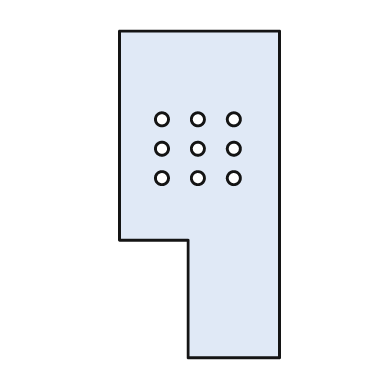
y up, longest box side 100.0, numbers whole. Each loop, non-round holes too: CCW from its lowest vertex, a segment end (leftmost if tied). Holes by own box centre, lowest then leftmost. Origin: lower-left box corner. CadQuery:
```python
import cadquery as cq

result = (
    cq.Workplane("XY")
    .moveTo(21.0, 0.0)
    .lineTo(49.0, 0.0)
    .lineTo(49.0, 100.0)
    .lineTo(0.0, 100.0)
    .lineTo(0.0, 36.0)
    .lineTo(21.0, 36.0)
    .close()
    .moveTo(13.0, 55.0)
    .circle(2.0)
    .moveTo(24.0, 55.0)
    .circle(2.0)
    .moveTo(35.0, 55.0)
    .circle(2.0)
    .moveTo(13.0, 64.0)
    .circle(2.0)
    .moveTo(24.0, 64.0)
    .circle(2.0)
    .moveTo(35.0, 64.0)
    .circle(2.0)
    .moveTo(13.0, 73.0)
    .circle(2.0)
    .moveTo(24.0, 73.0)
    .circle(2.0)
    .moveTo(35.0, 73.0)
    .circle(2.0)
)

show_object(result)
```